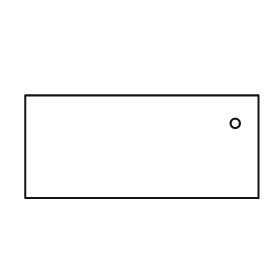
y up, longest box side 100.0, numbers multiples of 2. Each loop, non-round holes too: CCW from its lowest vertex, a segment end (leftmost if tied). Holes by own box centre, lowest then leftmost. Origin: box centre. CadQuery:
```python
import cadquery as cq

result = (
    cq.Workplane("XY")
    .moveTo(-50.0, -22.0)
    .lineTo(50.0, -22.0)
    .lineTo(50.0, 22.0)
    .lineTo(-50.0, 22.0)
    .close()
    .moveTo(40.0, 10.0)
    .circle(2.0)
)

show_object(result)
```